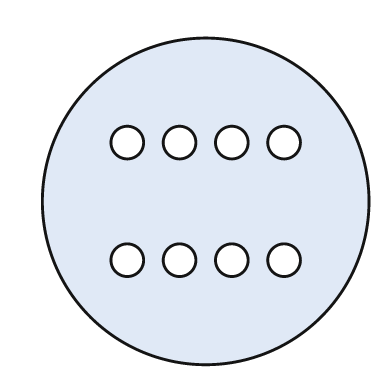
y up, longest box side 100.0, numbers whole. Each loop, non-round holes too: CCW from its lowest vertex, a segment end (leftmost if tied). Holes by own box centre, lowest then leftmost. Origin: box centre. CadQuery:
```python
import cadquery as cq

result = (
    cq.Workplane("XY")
    .moveTo(0.0, 0.0)
    .circle(50.0)
    .moveTo(-24.0, -18.0)
    .circle(5.0)
    .moveTo(-8.0, -18.0)
    .circle(5.0)
    .moveTo(8.0, -18.0)
    .circle(5.0)
    .moveTo(24.0, -18.0)
    .circle(5.0)
    .moveTo(-24.0, 18.0)
    .circle(5.0)
    .moveTo(-8.0, 18.0)
    .circle(5.0)
    .moveTo(8.0, 18.0)
    .circle(5.0)
    .moveTo(24.0, 18.0)
    .circle(5.0)
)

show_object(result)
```